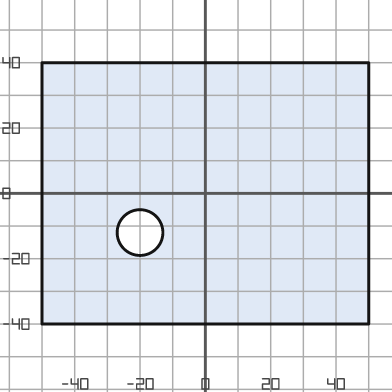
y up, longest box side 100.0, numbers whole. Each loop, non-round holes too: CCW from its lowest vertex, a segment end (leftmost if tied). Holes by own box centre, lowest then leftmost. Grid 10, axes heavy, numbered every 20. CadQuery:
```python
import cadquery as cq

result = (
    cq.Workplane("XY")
    .moveTo(-50.0, -40.0)
    .lineTo(50.0, -40.0)
    .lineTo(50.0, 40.0)
    .lineTo(-50.0, 40.0)
    .close()
    .moveTo(-20.0, -12.0)
    .circle(7.0)
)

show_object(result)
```